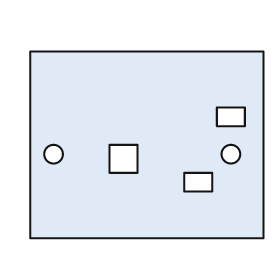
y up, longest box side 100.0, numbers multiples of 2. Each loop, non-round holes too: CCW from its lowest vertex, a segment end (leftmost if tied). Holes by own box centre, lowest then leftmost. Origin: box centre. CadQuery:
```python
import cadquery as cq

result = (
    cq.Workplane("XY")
    .moveTo(-50.0, -40.0)
    .lineTo(50.0, -40.0)
    .lineTo(50.0, 40.0)
    .lineTo(-50.0, 40.0)
    .close()
    .moveTo(16.0, -20.0)
    .lineTo(28.0, -20.0)
    .lineTo(28.0, -12.0)
    .lineTo(16.0, -12.0)
    .close()
    .moveTo(-16.0, -12.0)
    .lineTo(-4.0, -12.0)
    .lineTo(-4.0, 0.0)
    .lineTo(-16.0, 0.0)
    .close()
    .moveTo(-40.0, -4.0)
    .circle(4.0)
    .moveTo(36.0, -4.0)
    .circle(4.0)
    .moveTo(30.0, 8.0)
    .lineTo(42.0, 8.0)
    .lineTo(42.0, 16.0)
    .lineTo(30.0, 16.0)
    .close()
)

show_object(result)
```